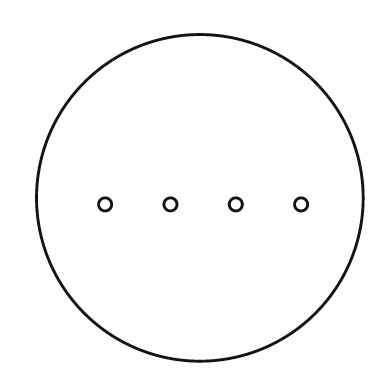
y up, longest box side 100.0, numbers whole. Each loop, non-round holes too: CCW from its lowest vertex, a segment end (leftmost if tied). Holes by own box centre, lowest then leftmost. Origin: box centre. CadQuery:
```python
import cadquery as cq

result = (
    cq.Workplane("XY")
    .moveTo(0.0, 0.0)
    .circle(50.0)
    .moveTo(-29.0, -2.0)
    .circle(2.0)
    .moveTo(-9.0, -2.0)
    .circle(2.0)
    .moveTo(11.0, -2.0)
    .circle(2.0)
    .moveTo(31.0, -2.0)
    .circle(2.0)
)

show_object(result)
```